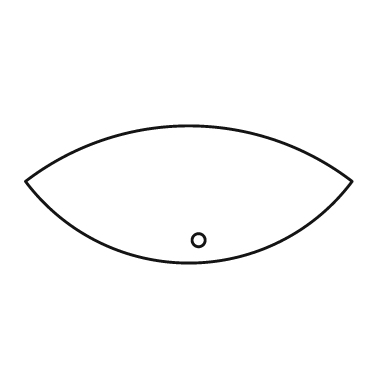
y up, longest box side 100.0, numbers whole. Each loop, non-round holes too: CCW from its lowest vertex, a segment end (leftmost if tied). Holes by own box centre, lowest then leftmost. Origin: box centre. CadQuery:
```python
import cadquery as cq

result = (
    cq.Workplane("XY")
    .moveTo(-50.0, 4.0)
    .threePointArc((0.0, -21.0), (50.0, 4.0))
    .threePointArc((0.0, 21.0), (-50.0, 4.0))
    .close()
    .moveTo(3.0, -14.0)
    .circle(2.0)
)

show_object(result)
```